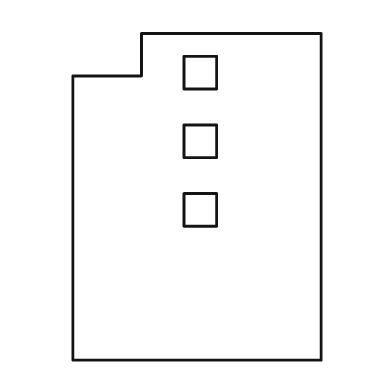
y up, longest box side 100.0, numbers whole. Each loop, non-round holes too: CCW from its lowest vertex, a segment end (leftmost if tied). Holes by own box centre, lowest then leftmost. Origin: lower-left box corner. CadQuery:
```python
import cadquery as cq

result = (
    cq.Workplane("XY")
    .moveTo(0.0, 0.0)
    .lineTo(76.0, 0.0)
    .lineTo(76.0, 100.0)
    .lineTo(21.0, 100.0)
    .lineTo(21.0, 87.0)
    .lineTo(0.0, 87.0)
    .close()
    .moveTo(34.0, 41.0)
    .lineTo(44.0, 41.0)
    .lineTo(44.0, 51.0)
    .lineTo(34.0, 51.0)
    .close()
    .moveTo(34.0, 62.0)
    .lineTo(44.0, 62.0)
    .lineTo(44.0, 72.0)
    .lineTo(34.0, 72.0)
    .close()
    .moveTo(34.0, 83.0)
    .lineTo(44.0, 83.0)
    .lineTo(44.0, 93.0)
    .lineTo(34.0, 93.0)
    .close()
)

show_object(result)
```